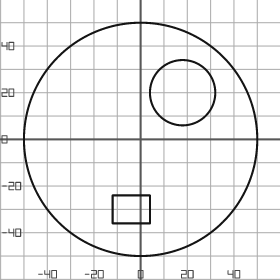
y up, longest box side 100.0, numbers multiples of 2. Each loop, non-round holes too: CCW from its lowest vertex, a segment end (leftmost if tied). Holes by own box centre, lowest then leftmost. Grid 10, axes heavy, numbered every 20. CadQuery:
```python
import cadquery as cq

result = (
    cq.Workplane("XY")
    .moveTo(0.0, 0.0)
    .circle(50.0)
    .moveTo(-12.0, -36.0)
    .lineTo(4.0, -36.0)
    .lineTo(4.0, -24.0)
    .lineTo(-12.0, -24.0)
    .close()
    .moveTo(18.0, 20.0)
    .circle(14.0)
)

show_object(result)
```